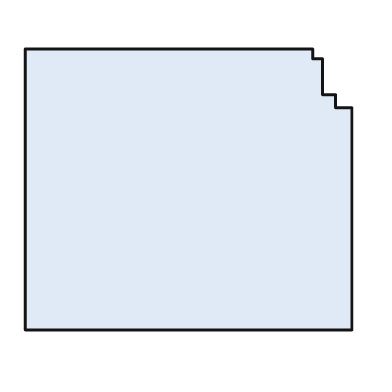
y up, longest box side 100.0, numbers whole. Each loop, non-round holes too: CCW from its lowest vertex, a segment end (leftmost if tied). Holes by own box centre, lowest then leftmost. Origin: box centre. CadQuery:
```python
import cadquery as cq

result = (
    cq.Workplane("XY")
    .moveTo(-50.0, -43.0)
    .lineTo(50.0, -43.0)
    .lineTo(50.0, 25.0)
    .lineTo(45.0, 25.0)
    .lineTo(45.0, 29.0)
    .lineTo(41.0, 29.0)
    .lineTo(41.0, 40.0)
    .lineTo(38.0, 40.0)
    .lineTo(38.0, 43.0)
    .lineTo(-50.0, 43.0)
    .close()
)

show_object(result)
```